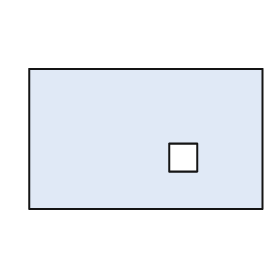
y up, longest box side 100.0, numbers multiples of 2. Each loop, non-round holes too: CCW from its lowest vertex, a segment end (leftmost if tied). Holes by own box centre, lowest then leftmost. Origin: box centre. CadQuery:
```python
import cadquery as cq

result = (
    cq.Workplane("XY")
    .moveTo(-50.0, -30.0)
    .lineTo(50.0, -30.0)
    .lineTo(50.0, 30.0)
    .lineTo(-50.0, 30.0)
    .close()
    .moveTo(10.0, -14.0)
    .lineTo(22.0, -14.0)
    .lineTo(22.0, -2.0)
    .lineTo(10.0, -2.0)
    .close()
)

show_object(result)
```